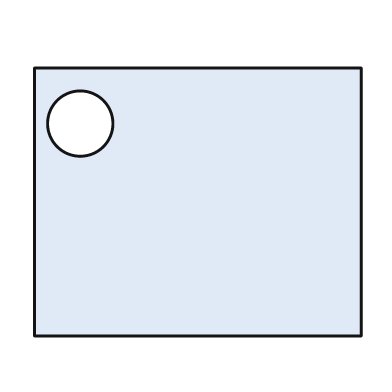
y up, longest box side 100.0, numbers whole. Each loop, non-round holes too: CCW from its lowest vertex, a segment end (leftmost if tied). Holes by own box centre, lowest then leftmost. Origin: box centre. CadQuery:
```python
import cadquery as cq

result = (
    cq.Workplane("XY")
    .moveTo(-50.0, -41.0)
    .lineTo(50.0, -41.0)
    .lineTo(50.0, 41.0)
    .lineTo(-50.0, 41.0)
    .close()
    .moveTo(-36.0, 24.0)
    .circle(10.0)
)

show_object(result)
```